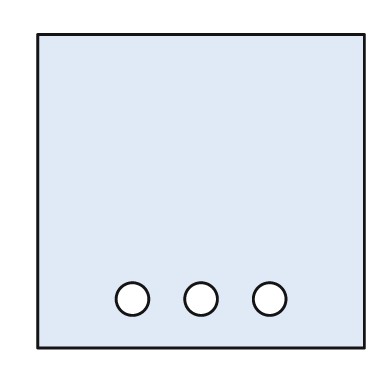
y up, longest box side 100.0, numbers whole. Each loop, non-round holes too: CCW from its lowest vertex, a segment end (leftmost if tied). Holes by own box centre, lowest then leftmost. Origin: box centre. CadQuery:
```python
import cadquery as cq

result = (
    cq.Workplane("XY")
    .moveTo(-50.0, -48.0)
    .lineTo(50.0, -48.0)
    .lineTo(50.0, 48.0)
    .lineTo(-50.0, 48.0)
    .close()
    .moveTo(-21.0, -33.0)
    .circle(5.0)
    .moveTo(0.0, -33.0)
    .circle(5.0)
    .moveTo(21.0, -33.0)
    .circle(5.0)
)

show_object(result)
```